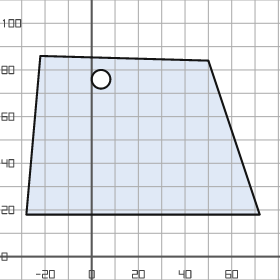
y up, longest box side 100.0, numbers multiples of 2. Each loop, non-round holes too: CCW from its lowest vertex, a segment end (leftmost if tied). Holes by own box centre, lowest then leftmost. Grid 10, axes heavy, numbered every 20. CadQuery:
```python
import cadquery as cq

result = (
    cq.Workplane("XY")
    .moveTo(-28.0, 18.0)
    .lineTo(72.0, 18.0)
    .lineTo(50.0, 84.0)
    .lineTo(-22.0, 86.0)
    .close()
    .moveTo(4.0, 76.0)
    .circle(4.0)
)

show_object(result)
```